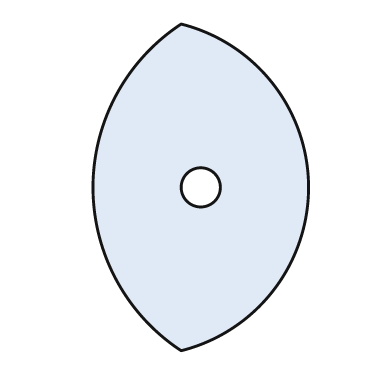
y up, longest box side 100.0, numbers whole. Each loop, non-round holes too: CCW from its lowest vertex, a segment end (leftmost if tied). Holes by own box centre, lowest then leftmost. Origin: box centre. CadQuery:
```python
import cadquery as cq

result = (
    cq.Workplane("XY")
    .moveTo(-6.0, -50.0)
    .threePointArc((33.0, 0.0), (-6.0, 50.0))
    .threePointArc((-33.0, 0.0), (-6.0, -50.0))
    .close()
    .moveTo(0.0, 0.0)
    .circle(6.0)
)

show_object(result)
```